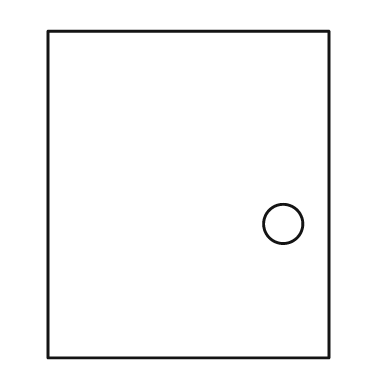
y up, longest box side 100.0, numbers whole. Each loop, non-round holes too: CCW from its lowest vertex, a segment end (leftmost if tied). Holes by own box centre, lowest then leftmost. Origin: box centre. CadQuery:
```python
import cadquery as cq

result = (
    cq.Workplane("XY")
    .moveTo(-43.0, -50.0)
    .lineTo(43.0, -50.0)
    .lineTo(43.0, 50.0)
    .lineTo(-43.0, 50.0)
    .close()
    .moveTo(29.0, -9.0)
    .circle(6.0)
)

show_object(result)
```